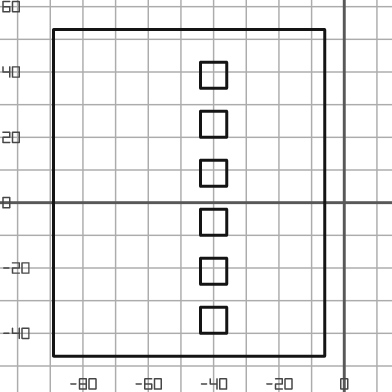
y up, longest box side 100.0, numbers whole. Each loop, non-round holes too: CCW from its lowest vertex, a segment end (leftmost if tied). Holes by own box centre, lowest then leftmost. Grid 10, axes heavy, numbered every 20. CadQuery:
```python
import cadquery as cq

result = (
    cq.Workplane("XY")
    .moveTo(-89.0, -47.0)
    .lineTo(-6.0, -47.0)
    .lineTo(-6.0, 53.0)
    .lineTo(-89.0, 53.0)
    .close()
    .moveTo(-44.0, -40.0)
    .lineTo(-36.0, -40.0)
    .lineTo(-36.0, -32.0)
    .lineTo(-44.0, -32.0)
    .close()
    .moveTo(-44.0, -25.0)
    .lineTo(-36.0, -25.0)
    .lineTo(-36.0, -17.0)
    .lineTo(-44.0, -17.0)
    .close()
    .moveTo(-44.0, -10.0)
    .lineTo(-36.0, -10.0)
    .lineTo(-36.0, -2.0)
    .lineTo(-44.0, -2.0)
    .close()
    .moveTo(-44.0, 5.0)
    .lineTo(-36.0, 5.0)
    .lineTo(-36.0, 13.0)
    .lineTo(-44.0, 13.0)
    .close()
    .moveTo(-44.0, 20.0)
    .lineTo(-36.0, 20.0)
    .lineTo(-36.0, 28.0)
    .lineTo(-44.0, 28.0)
    .close()
    .moveTo(-44.0, 35.0)
    .lineTo(-36.0, 35.0)
    .lineTo(-36.0, 43.0)
    .lineTo(-44.0, 43.0)
    .close()
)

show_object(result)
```